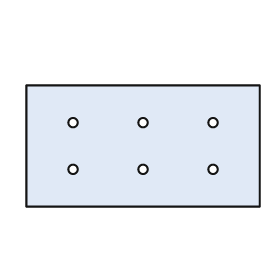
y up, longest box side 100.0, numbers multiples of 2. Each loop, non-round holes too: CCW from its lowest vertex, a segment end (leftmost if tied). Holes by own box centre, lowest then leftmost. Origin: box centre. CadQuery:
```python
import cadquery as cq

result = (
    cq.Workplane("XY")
    .moveTo(-50.0, -26.0)
    .lineTo(50.0, -26.0)
    .lineTo(50.0, 26.0)
    .lineTo(-50.0, 26.0)
    .close()
    .moveTo(-30.0, -10.0)
    .circle(2.0)
    .moveTo(0.0, -10.0)
    .circle(2.0)
    .moveTo(30.0, -10.0)
    .circle(2.0)
    .moveTo(-30.0, 10.0)
    .circle(2.0)
    .moveTo(0.0, 10.0)
    .circle(2.0)
    .moveTo(30.0, 10.0)
    .circle(2.0)
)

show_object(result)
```